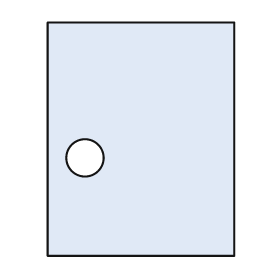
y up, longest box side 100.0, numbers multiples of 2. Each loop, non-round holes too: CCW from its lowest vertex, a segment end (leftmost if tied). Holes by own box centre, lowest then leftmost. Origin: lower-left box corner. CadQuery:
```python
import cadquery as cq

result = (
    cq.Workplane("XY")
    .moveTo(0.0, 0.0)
    .lineTo(80.0, 0.0)
    .lineTo(80.0, 100.0)
    .lineTo(0.0, 100.0)
    .close()
    .moveTo(16.0, 42.0)
    .circle(8.0)
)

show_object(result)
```